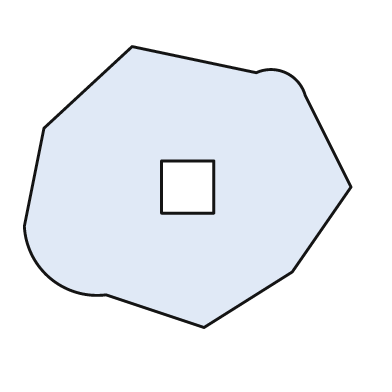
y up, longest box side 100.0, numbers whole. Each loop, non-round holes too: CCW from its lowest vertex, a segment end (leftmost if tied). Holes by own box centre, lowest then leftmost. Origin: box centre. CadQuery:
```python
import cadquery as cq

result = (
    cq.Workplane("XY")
    .moveTo(5.0, -43.0)
    .lineTo(32.0, -26.0)
    .lineTo(50.0, 0.0)
    .lineTo(36.0, 28.0)
    .threePointArc((30.0, 35.0), (21.0, 35.0))
    .lineTo(-17.0, 43.0)
    .lineTo(-44.0, 18.0)
    .lineTo(-50.0, -12.0)
    .threePointArc((-42.0, -28.0), (-25.0, -33.0))
    .close()
    .moveTo(-8.0, -8.0)
    .lineTo(8.0, -8.0)
    .lineTo(8.0, 8.0)
    .lineTo(-8.0, 8.0)
    .close()
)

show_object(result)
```